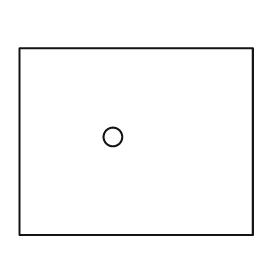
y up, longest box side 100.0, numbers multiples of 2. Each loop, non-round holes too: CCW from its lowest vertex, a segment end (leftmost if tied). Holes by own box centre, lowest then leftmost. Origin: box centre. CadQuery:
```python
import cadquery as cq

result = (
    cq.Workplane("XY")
    .moveTo(-50.0, -40.0)
    .lineTo(50.0, -40.0)
    .lineTo(50.0, 40.0)
    .lineTo(-50.0, 40.0)
    .close()
    .moveTo(-10.0, 2.0)
    .circle(4.0)
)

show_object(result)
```